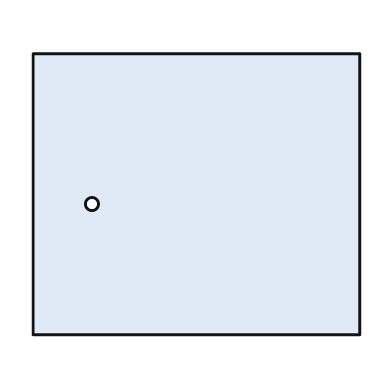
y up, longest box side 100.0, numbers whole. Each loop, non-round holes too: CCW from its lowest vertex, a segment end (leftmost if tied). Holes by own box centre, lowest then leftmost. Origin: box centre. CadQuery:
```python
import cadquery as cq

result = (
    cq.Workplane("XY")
    .moveTo(-50.0, -43.0)
    .lineTo(50.0, -43.0)
    .lineTo(50.0, 43.0)
    .lineTo(-50.0, 43.0)
    .close()
    .moveTo(-32.0, -3.0)
    .circle(2.0)
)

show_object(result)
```